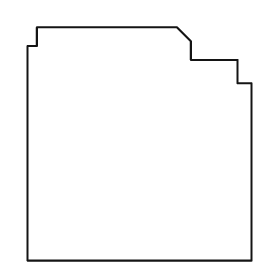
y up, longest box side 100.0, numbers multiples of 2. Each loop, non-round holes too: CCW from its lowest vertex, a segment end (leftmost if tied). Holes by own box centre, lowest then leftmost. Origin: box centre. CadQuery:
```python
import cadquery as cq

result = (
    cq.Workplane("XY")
    .moveTo(-48.0, -50.0)
    .lineTo(48.0, -50.0)
    .lineTo(48.0, 26.0)
    .lineTo(42.0, 26.0)
    .lineTo(42.0, 36.0)
    .lineTo(22.0, 36.0)
    .lineTo(22.0, 44.0)
    .lineTo(16.0, 50.0)
    .lineTo(-44.0, 50.0)
    .lineTo(-44.0, 42.0)
    .lineTo(-48.0, 42.0)
    .close()
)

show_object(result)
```